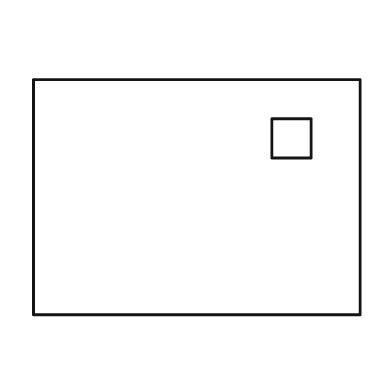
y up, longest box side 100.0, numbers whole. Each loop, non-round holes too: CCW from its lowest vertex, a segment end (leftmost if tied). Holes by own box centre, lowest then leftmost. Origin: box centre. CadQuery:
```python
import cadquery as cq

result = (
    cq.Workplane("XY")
    .moveTo(-50.0, -36.0)
    .lineTo(50.0, -36.0)
    .lineTo(50.0, 36.0)
    .lineTo(-50.0, 36.0)
    .close()
    .moveTo(23.0, 12.0)
    .lineTo(35.0, 12.0)
    .lineTo(35.0, 24.0)
    .lineTo(23.0, 24.0)
    .close()
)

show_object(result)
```